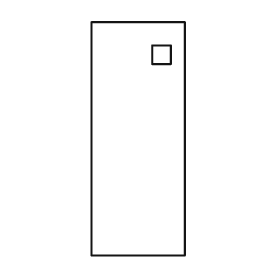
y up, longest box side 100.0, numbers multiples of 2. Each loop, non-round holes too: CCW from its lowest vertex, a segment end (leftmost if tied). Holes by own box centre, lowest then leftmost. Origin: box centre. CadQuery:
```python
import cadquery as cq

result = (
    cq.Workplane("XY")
    .moveTo(-20.0, -50.0)
    .lineTo(20.0, -50.0)
    .lineTo(20.0, 50.0)
    .lineTo(-20.0, 50.0)
    .close()
    .moveTo(6.0, 32.0)
    .lineTo(14.0, 32.0)
    .lineTo(14.0, 40.0)
    .lineTo(6.0, 40.0)
    .close()
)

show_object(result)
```